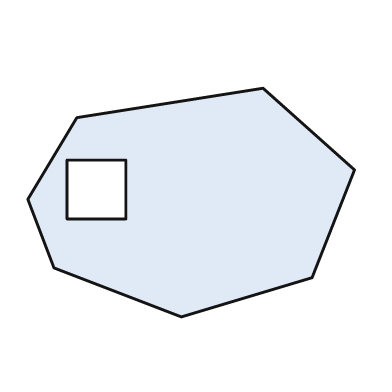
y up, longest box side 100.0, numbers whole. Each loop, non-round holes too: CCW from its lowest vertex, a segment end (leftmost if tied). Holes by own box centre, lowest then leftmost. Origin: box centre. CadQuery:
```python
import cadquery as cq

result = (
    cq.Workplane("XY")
    .moveTo(-3.0, -35.0)
    .lineTo(37.0, -23.0)
    .lineTo(50.0, 10.0)
    .lineTo(22.0, 35.0)
    .lineTo(-35.0, 26.0)
    .lineTo(-50.0, 1.0)
    .lineTo(-42.0, -20.0)
    .close()
    .moveTo(-38.0, -5.0)
    .lineTo(-20.0, -5.0)
    .lineTo(-20.0, 13.0)
    .lineTo(-38.0, 13.0)
    .close()
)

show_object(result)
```